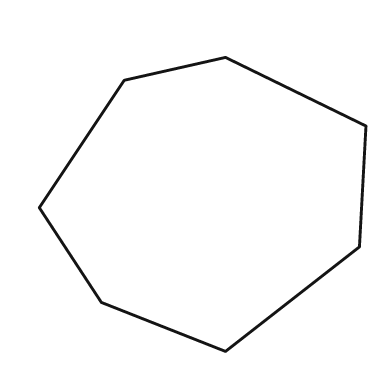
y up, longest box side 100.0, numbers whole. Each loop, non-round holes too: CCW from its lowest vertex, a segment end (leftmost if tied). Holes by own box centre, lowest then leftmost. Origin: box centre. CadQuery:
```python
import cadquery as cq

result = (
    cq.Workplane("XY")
    .moveTo(7.0, -45.0)
    .lineTo(48.0, -13.0)
    .lineTo(50.0, 24.0)
    .lineTo(7.0, 45.0)
    .lineTo(-24.0, 38.0)
    .lineTo(-50.0, -1.0)
    .lineTo(-31.0, -30.0)
    .close()
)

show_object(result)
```